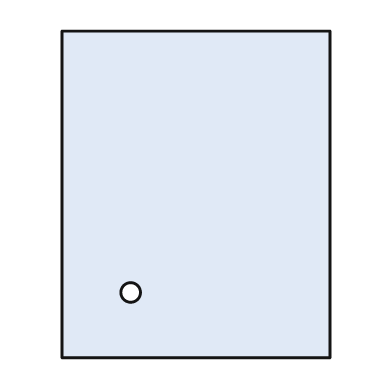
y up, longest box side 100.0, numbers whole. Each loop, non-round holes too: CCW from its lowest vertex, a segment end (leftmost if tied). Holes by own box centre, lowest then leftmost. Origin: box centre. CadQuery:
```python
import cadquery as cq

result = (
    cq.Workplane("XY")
    .moveTo(-41.0, -50.0)
    .lineTo(41.0, -50.0)
    .lineTo(41.0, 50.0)
    .lineTo(-41.0, 50.0)
    .close()
    .moveTo(-20.0, -30.0)
    .circle(3.0)
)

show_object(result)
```